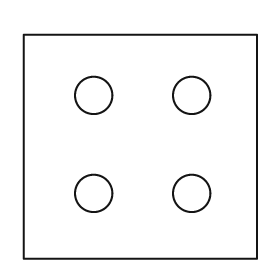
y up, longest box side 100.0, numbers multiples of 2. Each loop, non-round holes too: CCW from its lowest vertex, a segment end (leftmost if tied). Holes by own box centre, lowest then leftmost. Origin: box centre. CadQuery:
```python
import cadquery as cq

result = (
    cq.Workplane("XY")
    .moveTo(-50.0, -48.0)
    .lineTo(50.0, -48.0)
    .lineTo(50.0, 48.0)
    .lineTo(-50.0, 48.0)
    .close()
    .moveTo(-20.0, -20.0)
    .circle(8.0)
    .moveTo(22.0, -20.0)
    .circle(8.0)
    .moveTo(-20.0, 22.0)
    .circle(8.0)
    .moveTo(22.0, 22.0)
    .circle(8.0)
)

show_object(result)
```